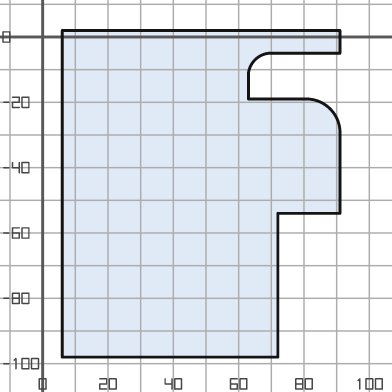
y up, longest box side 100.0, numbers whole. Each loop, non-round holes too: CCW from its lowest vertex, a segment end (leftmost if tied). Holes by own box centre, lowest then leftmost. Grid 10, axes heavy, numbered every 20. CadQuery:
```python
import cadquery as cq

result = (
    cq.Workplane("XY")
    .moveTo(6.0, -98.0)
    .lineTo(72.0, -98.0)
    .lineTo(72.0, -54.0)
    .lineTo(91.0, -54.0)
    .lineTo(91.0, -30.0)
    .threePointArc((88.0, -22.0), (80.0, -19.0))
    .lineTo(63.0, -19.0)
    .lineTo(63.0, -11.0)
    .threePointArc((65.0, -7.0), (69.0, -5.0))
    .lineTo(91.0, -5.0)
    .lineTo(91.0, 2.0)
    .lineTo(6.0, 2.0)
    .close()
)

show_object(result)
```